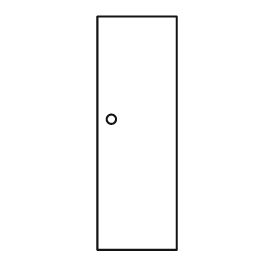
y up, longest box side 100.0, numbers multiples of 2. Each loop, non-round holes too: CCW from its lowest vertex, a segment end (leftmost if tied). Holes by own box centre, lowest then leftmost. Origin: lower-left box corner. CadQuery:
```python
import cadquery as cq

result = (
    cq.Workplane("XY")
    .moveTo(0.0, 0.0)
    .lineTo(34.0, 0.0)
    .lineTo(34.0, 100.0)
    .lineTo(0.0, 100.0)
    .close()
    .moveTo(6.0, 56.0)
    .circle(2.0)
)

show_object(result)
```